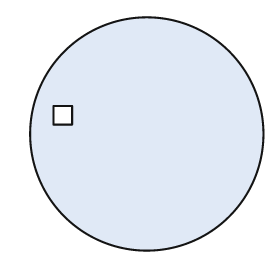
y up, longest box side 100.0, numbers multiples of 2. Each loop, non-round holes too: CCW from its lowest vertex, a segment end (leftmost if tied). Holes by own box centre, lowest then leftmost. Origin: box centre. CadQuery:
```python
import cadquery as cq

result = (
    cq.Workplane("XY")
    .moveTo(0.0, 0.0)
    .circle(50.0)
    .moveTo(-40.0, 4.0)
    .lineTo(-32.0, 4.0)
    .lineTo(-32.0, 12.0)
    .lineTo(-40.0, 12.0)
    .close()
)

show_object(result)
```